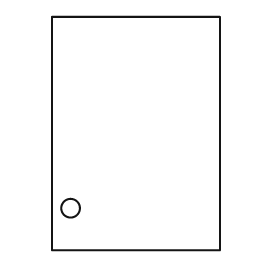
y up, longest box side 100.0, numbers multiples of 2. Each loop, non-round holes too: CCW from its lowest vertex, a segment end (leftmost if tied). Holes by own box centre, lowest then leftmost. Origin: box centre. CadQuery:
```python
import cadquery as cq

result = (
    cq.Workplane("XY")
    .moveTo(-36.0, -50.0)
    .lineTo(36.0, -50.0)
    .lineTo(36.0, 50.0)
    .lineTo(-36.0, 50.0)
    .close()
    .moveTo(-28.0, -32.0)
    .circle(4.0)
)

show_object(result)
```